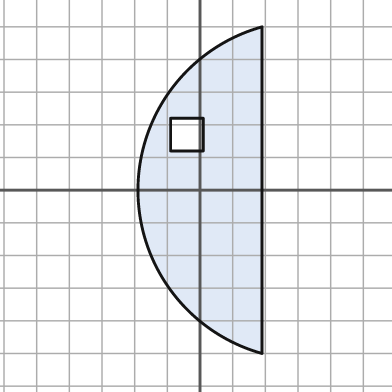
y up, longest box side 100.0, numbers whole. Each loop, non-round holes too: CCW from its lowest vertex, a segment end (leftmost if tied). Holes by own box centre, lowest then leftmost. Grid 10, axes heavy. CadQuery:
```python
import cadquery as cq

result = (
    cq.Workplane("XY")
    .moveTo(19.0, -50.0)
    .lineTo(19.0, 50.0)
    .threePointArc((-19.0, 0.0), (19.0, -50.0))
    .close()
    .moveTo(-9.0, 12.0)
    .lineTo(1.0, 12.0)
    .lineTo(1.0, 22.0)
    .lineTo(-9.0, 22.0)
    .close()
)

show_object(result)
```